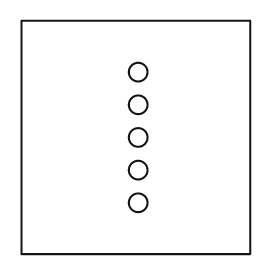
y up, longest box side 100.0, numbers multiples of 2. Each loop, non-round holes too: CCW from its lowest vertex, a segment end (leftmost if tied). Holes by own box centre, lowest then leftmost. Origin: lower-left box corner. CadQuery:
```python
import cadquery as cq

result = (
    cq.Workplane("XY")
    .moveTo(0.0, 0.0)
    .lineTo(98.0, 0.0)
    .lineTo(98.0, 100.0)
    .lineTo(0.0, 100.0)
    .close()
    .moveTo(50.0, 22.0)
    .circle(4.0)
    .moveTo(50.0, 36.0)
    .circle(4.0)
    .moveTo(50.0, 50.0)
    .circle(4.0)
    .moveTo(50.0, 64.0)
    .circle(4.0)
    .moveTo(50.0, 78.0)
    .circle(4.0)
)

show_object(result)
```